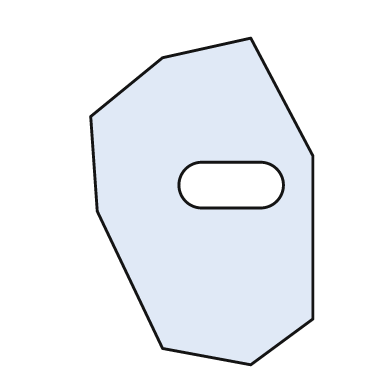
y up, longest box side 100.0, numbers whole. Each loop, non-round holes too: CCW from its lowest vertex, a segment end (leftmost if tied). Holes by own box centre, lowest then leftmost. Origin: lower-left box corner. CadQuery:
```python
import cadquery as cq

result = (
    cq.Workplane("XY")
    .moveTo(49.0, 0.0)
    .lineTo(68.0, 14.0)
    .lineTo(68.0, 64.0)
    .lineTo(49.0, 100.0)
    .lineTo(22.0, 94.0)
    .lineTo(0.0, 76.0)
    .lineTo(2.0, 47.0)
    .lineTo(22.0, 5.0)
    .close()
    .moveTo(34.0, 48.0)
    .lineTo(52.0, 48.0)
    .threePointArc((59.0, 55.0), (52.0, 62.0))
    .lineTo(34.0, 62.0)
    .threePointArc((27.0, 55.0), (34.0, 48.0))
    .close()
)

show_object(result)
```